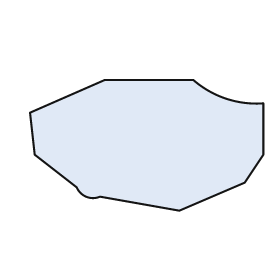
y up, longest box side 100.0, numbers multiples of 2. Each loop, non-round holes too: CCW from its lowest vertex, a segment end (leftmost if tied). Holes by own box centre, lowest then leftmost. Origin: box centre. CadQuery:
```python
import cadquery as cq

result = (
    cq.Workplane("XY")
    .moveTo(14.0, -28.0)
    .lineTo(42.0, -16.0)
    .lineTo(50.0, -4.0)
    .lineTo(50.0, 18.0)
    .threePointArc((34.0, 20.0), (20.0, 28.0))
    .lineTo(-18.0, 28.0)
    .lineTo(-50.0, 14.0)
    .lineTo(-48.0, -4.0)
    .lineTo(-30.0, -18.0)
    .threePointArc((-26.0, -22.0), (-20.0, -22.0))
    .close()
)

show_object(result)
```